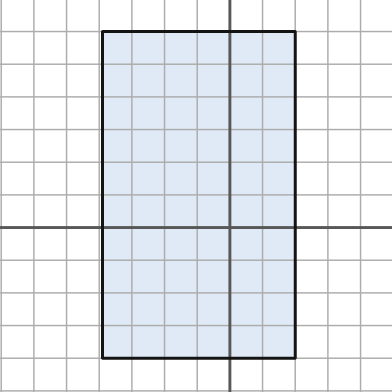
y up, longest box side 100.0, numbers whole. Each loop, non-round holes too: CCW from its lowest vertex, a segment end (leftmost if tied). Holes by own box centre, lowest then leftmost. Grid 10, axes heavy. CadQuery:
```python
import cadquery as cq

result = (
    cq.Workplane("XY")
    .moveTo(-39.0, -40.0)
    .lineTo(20.0, -40.0)
    .lineTo(20.0, 60.0)
    .lineTo(-39.0, 60.0)
    .close()
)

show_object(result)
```